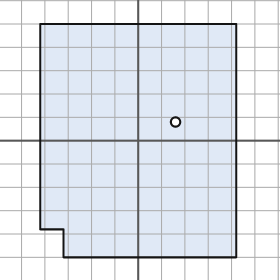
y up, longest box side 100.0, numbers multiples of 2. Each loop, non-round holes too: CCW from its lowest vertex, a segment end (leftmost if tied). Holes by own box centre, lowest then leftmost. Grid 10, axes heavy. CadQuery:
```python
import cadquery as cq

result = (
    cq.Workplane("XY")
    .moveTo(-32.0, -50.0)
    .lineTo(42.0, -50.0)
    .lineTo(42.0, 50.0)
    .lineTo(-42.0, 50.0)
    .lineTo(-42.0, -38.0)
    .lineTo(-32.0, -38.0)
    .close()
    .moveTo(16.0, 8.0)
    .circle(2.0)
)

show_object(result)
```